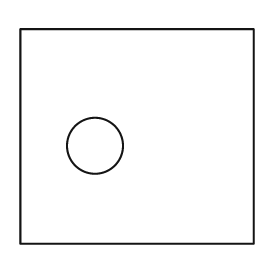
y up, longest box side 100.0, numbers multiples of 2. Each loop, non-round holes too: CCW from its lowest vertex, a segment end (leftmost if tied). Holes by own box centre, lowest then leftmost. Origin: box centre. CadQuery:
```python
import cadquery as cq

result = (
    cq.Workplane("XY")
    .moveTo(-50.0, -46.0)
    .lineTo(50.0, -46.0)
    .lineTo(50.0, 46.0)
    .lineTo(-50.0, 46.0)
    .close()
    .moveTo(-18.0, -4.0)
    .circle(12.0)
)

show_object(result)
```